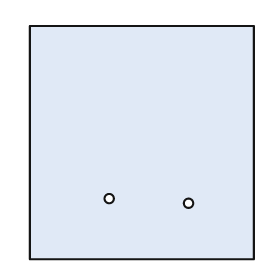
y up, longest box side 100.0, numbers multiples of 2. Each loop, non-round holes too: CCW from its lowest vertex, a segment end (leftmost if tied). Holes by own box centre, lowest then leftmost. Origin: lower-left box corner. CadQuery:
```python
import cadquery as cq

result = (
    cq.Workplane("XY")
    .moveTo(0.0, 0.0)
    .lineTo(96.0, 0.0)
    .lineTo(96.0, 100.0)
    .lineTo(0.0, 100.0)
    .close()
    .moveTo(68.0, 24.0)
    .circle(2.0)
    .moveTo(34.0, 26.0)
    .circle(2.0)
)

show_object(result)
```